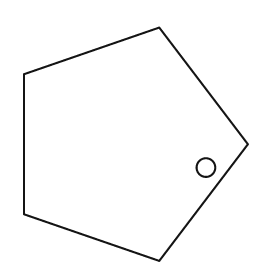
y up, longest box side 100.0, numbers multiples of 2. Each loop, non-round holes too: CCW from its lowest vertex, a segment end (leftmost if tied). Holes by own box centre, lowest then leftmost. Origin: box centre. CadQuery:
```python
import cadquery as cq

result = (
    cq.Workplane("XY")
    .moveTo(10.0, -50.0)
    .lineTo(48.0, 0.0)
    .lineTo(10.0, 50.0)
    .lineTo(-48.0, 30.0)
    .lineTo(-48.0, -30.0)
    .close()
    .moveTo(30.0, -10.0)
    .circle(4.0)
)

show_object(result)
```